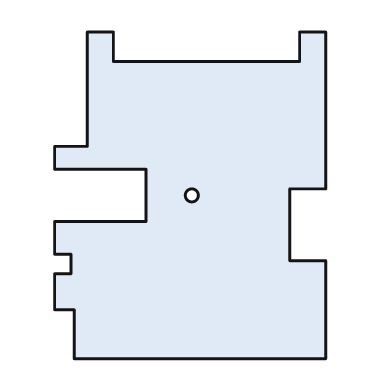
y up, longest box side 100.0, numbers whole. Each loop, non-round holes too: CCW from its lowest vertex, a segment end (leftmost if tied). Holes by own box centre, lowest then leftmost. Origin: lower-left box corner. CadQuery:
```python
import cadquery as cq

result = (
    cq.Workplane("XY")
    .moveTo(6.0, 0.0)
    .lineTo(83.0, 0.0)
    .lineTo(83.0, 30.0)
    .lineTo(72.0, 30.0)
    .lineTo(72.0, 52.0)
    .lineTo(83.0, 52.0)
    .lineTo(83.0, 100.0)
    .lineTo(75.0, 100.0)
    .lineTo(75.0, 91.0)
    .lineTo(18.0, 91.0)
    .lineTo(18.0, 100.0)
    .lineTo(10.0, 100.0)
    .lineTo(10.0, 65.0)
    .lineTo(0.0, 65.0)
    .lineTo(0.0, 58.0)
    .lineTo(28.0, 58.0)
    .lineTo(28.0, 42.0)
    .lineTo(0.0, 42.0)
    .lineTo(0.0, 32.0)
    .lineTo(5.0, 32.0)
    .lineTo(5.0, 26.0)
    .lineTo(0.0, 26.0)
    .lineTo(0.0, 15.0)
    .lineTo(6.0, 15.0)
    .close()
    .moveTo(42.0, 50.0)
    .circle(2.0)
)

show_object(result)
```